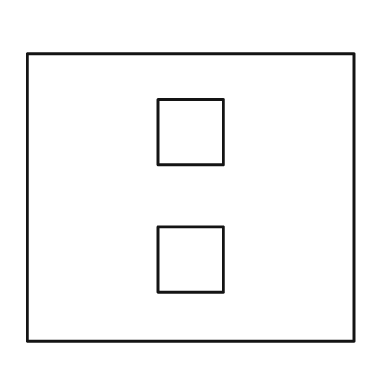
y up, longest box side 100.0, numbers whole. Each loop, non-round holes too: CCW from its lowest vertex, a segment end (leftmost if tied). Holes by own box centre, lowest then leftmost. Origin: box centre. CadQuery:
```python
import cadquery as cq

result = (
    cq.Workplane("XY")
    .moveTo(-50.0, -44.0)
    .lineTo(50.0, -44.0)
    .lineTo(50.0, 44.0)
    .lineTo(-50.0, 44.0)
    .close()
    .moveTo(-10.0, -29.0)
    .lineTo(10.0, -29.0)
    .lineTo(10.0, -9.0)
    .lineTo(-10.0, -9.0)
    .close()
    .moveTo(-10.0, 10.0)
    .lineTo(10.0, 10.0)
    .lineTo(10.0, 30.0)
    .lineTo(-10.0, 30.0)
    .close()
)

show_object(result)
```